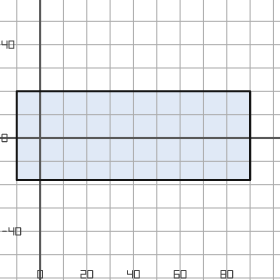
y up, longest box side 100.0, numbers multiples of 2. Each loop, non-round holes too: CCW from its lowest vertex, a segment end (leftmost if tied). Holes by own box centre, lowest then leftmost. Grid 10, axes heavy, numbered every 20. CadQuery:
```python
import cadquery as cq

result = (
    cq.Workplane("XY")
    .moveTo(-10.0, -18.0)
    .lineTo(90.0, -18.0)
    .lineTo(90.0, 20.0)
    .lineTo(-10.0, 20.0)
    .close()
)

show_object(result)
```